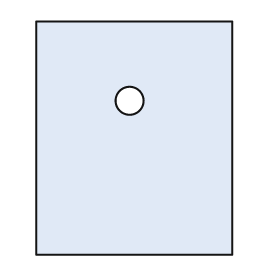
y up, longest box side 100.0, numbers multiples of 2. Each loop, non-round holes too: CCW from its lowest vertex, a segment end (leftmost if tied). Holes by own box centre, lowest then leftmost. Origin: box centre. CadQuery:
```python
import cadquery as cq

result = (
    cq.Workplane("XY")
    .moveTo(-42.0, -50.0)
    .lineTo(42.0, -50.0)
    .lineTo(42.0, 50.0)
    .lineTo(-42.0, 50.0)
    .close()
    .moveTo(-2.0, 16.0)
    .circle(6.0)
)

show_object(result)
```